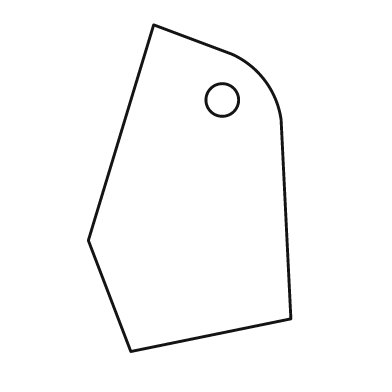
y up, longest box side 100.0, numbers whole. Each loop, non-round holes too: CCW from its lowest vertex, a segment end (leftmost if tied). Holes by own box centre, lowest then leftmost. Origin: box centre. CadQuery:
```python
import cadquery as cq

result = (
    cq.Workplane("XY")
    .moveTo(-18.0, -50.0)
    .lineTo(31.0, -40.0)
    .lineTo(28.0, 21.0)
    .threePointArc((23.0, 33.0), (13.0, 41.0))
    .lineTo(-11.0, 50.0)
    .lineTo(-31.0, -16.0)
    .close()
    .moveTo(10.0, 27.0)
    .circle(5.0)
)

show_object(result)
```